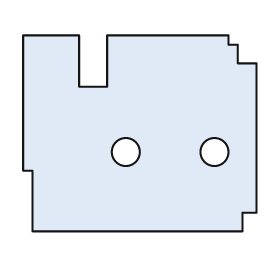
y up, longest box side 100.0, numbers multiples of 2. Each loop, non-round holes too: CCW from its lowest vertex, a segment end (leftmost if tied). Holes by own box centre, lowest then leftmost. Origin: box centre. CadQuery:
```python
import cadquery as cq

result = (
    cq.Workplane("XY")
    .moveTo(-46.0, -42.0)
    .lineTo(44.0, -42.0)
    .lineTo(44.0, -34.0)
    .lineTo(50.0, -34.0)
    .lineTo(50.0, 30.0)
    .lineTo(42.0, 30.0)
    .lineTo(42.0, 38.0)
    .lineTo(38.0, 38.0)
    .lineTo(38.0, 42.0)
    .lineTo(-14.0, 42.0)
    .lineTo(-14.0, 20.0)
    .lineTo(-26.0, 20.0)
    .lineTo(-26.0, 42.0)
    .lineTo(-50.0, 42.0)
    .lineTo(-50.0, -16.0)
    .lineTo(-46.0, -16.0)
    .close()
    .moveTo(-6.0, -8.0)
    .circle(6.0)
    .moveTo(32.0, -8.0)
    .circle(6.0)
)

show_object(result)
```